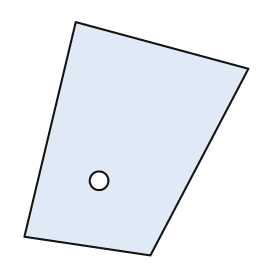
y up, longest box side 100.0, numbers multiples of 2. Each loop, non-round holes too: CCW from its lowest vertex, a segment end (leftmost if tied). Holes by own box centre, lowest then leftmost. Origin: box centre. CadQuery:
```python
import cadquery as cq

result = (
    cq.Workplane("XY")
    .moveTo(6.0, -50.0)
    .lineTo(48.0, 30.0)
    .lineTo(-26.0, 50.0)
    .lineTo(-48.0, -42.0)
    .close()
    .moveTo(-16.0, -18.0)
    .circle(4.0)
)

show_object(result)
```